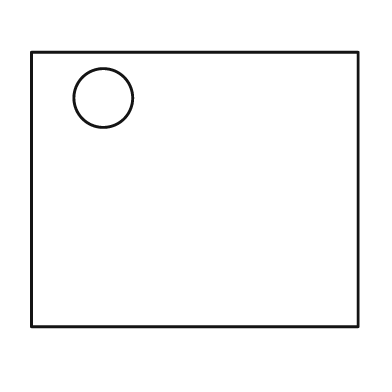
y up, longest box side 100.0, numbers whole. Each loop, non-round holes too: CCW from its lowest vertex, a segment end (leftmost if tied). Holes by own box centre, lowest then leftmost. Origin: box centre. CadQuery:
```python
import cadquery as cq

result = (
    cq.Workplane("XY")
    .moveTo(-50.0, -42.0)
    .lineTo(50.0, -42.0)
    .lineTo(50.0, 42.0)
    .lineTo(-50.0, 42.0)
    .close()
    .moveTo(-28.0, 28.0)
    .circle(9.0)
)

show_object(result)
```